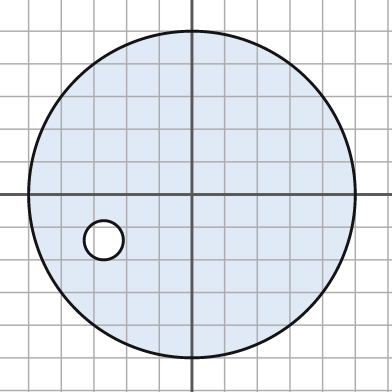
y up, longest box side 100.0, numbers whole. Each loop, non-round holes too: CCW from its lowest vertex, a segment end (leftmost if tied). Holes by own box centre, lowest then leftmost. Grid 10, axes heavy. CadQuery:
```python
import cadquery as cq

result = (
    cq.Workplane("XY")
    .moveTo(0.0, 0.0)
    .circle(50.0)
    .moveTo(-27.0, -14.0)
    .circle(6.0)
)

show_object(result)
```